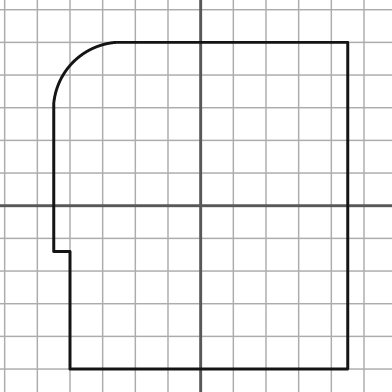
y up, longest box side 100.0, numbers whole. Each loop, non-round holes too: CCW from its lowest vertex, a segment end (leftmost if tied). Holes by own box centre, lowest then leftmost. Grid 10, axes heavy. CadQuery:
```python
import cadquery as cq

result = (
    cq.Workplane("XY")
    .moveTo(-40.0, -50.0)
    .lineTo(45.0, -50.0)
    .lineTo(45.0, 50.0)
    .lineTo(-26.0, 50.0)
    .threePointArc((-39.0, 44.0), (-45.0, 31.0))
    .lineTo(-45.0, -14.0)
    .lineTo(-40.0, -14.0)
    .close()
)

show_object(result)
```